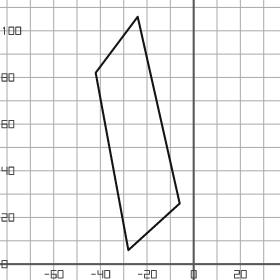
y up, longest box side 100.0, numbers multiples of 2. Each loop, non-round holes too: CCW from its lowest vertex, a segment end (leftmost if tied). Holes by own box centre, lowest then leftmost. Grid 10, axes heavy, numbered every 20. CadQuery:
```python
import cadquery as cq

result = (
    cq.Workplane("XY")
    .moveTo(-28.0, 6.0)
    .lineTo(-6.0, 26.0)
    .lineTo(-24.0, 106.0)
    .lineTo(-42.0, 82.0)
    .close()
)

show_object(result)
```